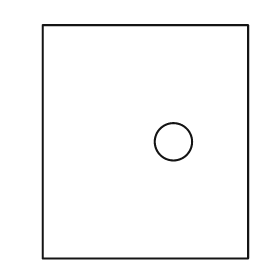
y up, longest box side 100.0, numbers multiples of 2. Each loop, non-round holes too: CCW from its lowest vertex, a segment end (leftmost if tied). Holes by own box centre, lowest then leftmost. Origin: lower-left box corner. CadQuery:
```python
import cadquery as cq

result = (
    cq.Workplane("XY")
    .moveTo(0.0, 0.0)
    .lineTo(88.0, 0.0)
    .lineTo(88.0, 100.0)
    .lineTo(0.0, 100.0)
    .close()
    .moveTo(56.0, 50.0)
    .circle(8.0)
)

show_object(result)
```